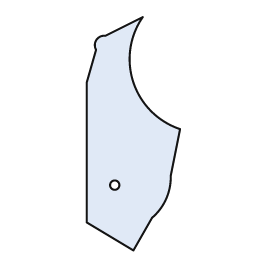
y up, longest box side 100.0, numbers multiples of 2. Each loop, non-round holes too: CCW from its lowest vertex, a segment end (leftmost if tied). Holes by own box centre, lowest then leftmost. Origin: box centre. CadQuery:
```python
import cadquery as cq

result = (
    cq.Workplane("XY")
    .moveTo(0.0, -50.0)
    .lineTo(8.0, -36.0)
    .threePointArc((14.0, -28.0), (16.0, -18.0))
    .lineTo(20.0, 2.0)
    .threePointArc((0.0, 22.0), (4.0, 50.0))
    .lineTo(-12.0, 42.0)
    .threePointArc((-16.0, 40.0), (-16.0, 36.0))
    .lineTo(-20.0, 22.0)
    .lineTo(-20.0, -38.0)
    .close()
    .moveTo(-8.0, -22.0)
    .circle(2.0)
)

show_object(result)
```